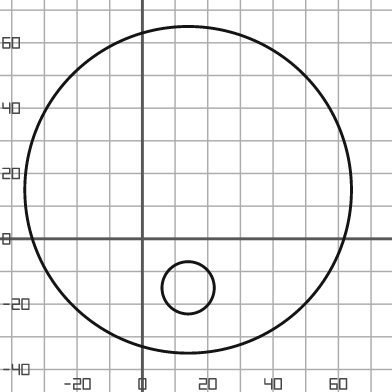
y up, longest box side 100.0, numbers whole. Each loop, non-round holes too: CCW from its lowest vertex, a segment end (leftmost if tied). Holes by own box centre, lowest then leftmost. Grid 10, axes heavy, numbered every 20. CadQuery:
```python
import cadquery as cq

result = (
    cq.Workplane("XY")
    .moveTo(14.0, 15.0)
    .circle(50.0)
    .moveTo(14.0, -15.0)
    .circle(8.0)
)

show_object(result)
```